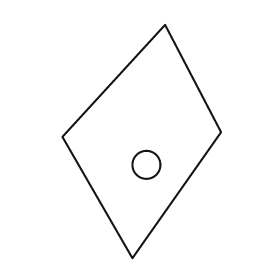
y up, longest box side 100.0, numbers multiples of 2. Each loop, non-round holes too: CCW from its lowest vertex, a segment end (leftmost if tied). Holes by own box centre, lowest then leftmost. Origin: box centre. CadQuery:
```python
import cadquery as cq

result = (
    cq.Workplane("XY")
    .moveTo(-4.0, -50.0)
    .lineTo(34.0, 4.0)
    .lineTo(10.0, 50.0)
    .lineTo(-34.0, 2.0)
    .close()
    .moveTo(2.0, -10.0)
    .circle(6.0)
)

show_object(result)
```